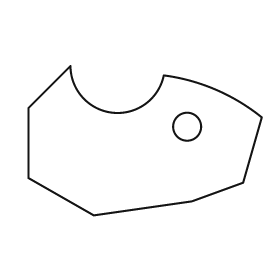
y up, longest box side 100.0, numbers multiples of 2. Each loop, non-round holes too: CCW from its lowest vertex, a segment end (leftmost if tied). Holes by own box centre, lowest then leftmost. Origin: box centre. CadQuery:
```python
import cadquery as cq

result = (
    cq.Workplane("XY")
    .moveTo(-22.0, -32.0)
    .lineTo(20.0, -26.0)
    .lineTo(42.0, -18.0)
    .lineTo(50.0, 10.0)
    .threePointArc((30.0, 22.0), (8.0, 28.0))
    .threePointArc((-14.0, 12.0), (-32.0, 32.0))
    .lineTo(-50.0, 14.0)
    .lineTo(-50.0, -16.0)
    .close()
    .moveTo(18.0, 6.0)
    .circle(6.0)
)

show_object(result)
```